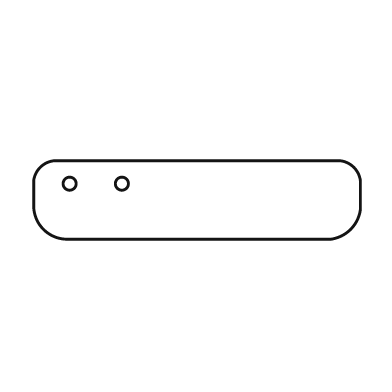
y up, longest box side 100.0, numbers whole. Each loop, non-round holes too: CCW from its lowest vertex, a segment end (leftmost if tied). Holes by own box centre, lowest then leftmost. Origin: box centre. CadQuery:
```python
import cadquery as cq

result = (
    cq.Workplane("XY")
    .moveTo(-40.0, -12.0)
    .lineTo(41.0, -12.0)
    .threePointArc((47.0, -9.0), (50.0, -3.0))
    .lineTo(50.0, 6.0)
    .threePointArc((48.0, 10.0), (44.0, 12.0))
    .lineTo(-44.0, 12.0)
    .threePointArc((-48.0, 10.0), (-50.0, 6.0))
    .lineTo(-50.0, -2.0)
    .threePointArc((-47.0, -9.0), (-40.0, -12.0))
    .close()
    .moveTo(-39.0, 5.0)
    .circle(2.0)
    .moveTo(-23.0, 5.0)
    .circle(2.0)
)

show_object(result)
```